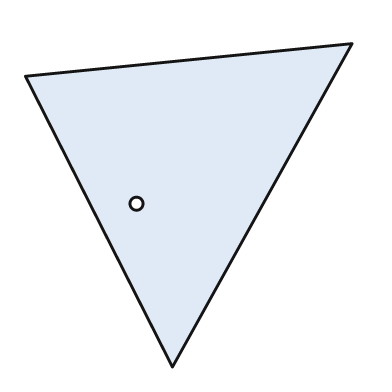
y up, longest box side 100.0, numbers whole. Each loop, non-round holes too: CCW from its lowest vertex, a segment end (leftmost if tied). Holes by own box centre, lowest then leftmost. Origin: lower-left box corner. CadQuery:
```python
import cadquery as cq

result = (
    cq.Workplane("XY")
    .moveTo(45.0, 0.0)
    .lineTo(100.0, 99.0)
    .lineTo(0.0, 89.0)
    .close()
    .moveTo(34.0, 50.0)
    .circle(2.0)
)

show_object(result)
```